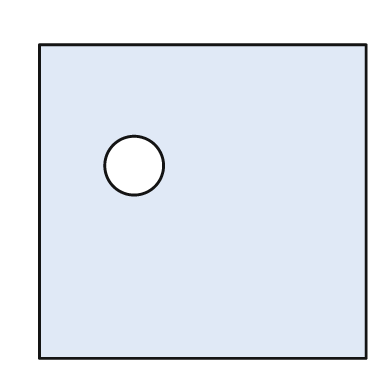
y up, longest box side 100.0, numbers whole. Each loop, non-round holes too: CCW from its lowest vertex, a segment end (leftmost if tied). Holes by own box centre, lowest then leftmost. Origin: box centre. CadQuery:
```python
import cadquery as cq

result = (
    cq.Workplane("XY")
    .moveTo(-50.0, -48.0)
    .lineTo(50.0, -48.0)
    .lineTo(50.0, 48.0)
    .lineTo(-50.0, 48.0)
    .close()
    .moveTo(-21.0, 11.0)
    .circle(9.0)
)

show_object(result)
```